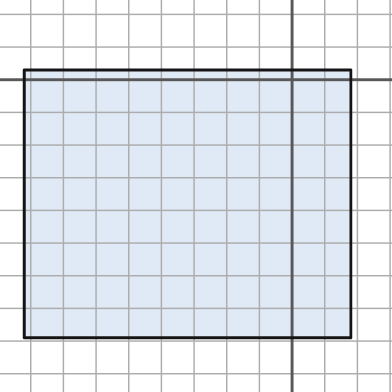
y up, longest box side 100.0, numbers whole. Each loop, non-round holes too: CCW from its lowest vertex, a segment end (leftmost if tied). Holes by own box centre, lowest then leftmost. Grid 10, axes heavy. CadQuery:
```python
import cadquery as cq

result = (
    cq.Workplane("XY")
    .moveTo(-82.0, -79.0)
    .lineTo(18.0, -79.0)
    .lineTo(18.0, 3.0)
    .lineTo(-82.0, 3.0)
    .close()
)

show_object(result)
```